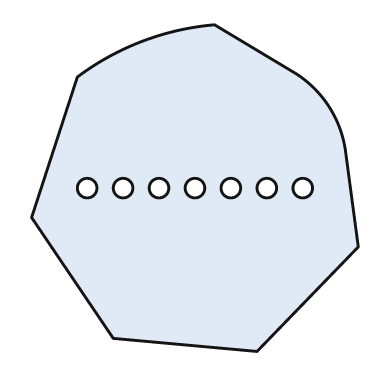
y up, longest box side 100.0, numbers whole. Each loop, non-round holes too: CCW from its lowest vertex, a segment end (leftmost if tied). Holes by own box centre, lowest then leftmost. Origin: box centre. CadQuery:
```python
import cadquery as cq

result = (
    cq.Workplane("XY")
    .moveTo(19.0, -50.0)
    .lineTo(50.0, -18.0)
    .lineTo(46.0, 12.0)
    .threePointArc((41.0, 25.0), (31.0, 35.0))
    .lineTo(6.0, 50.0)
    .threePointArc((-16.0, 45.0), (-36.0, 34.0))
    .lineTo(-50.0, -9.0)
    .lineTo(-25.0, -46.0)
    .close()
    .moveTo(-33.0, 0.0)
    .circle(3.0)
    .moveTo(-22.0, 0.0)
    .circle(3.0)
    .moveTo(-11.0, 0.0)
    .circle(3.0)
    .moveTo(0.0, 0.0)
    .circle(3.0)
    .moveTo(11.0, 0.0)
    .circle(3.0)
    .moveTo(22.0, 0.0)
    .circle(3.0)
    .moveTo(33.0, 0.0)
    .circle(3.0)
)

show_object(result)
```